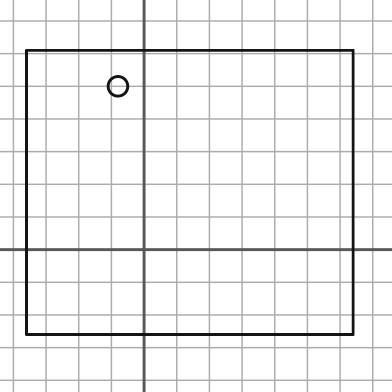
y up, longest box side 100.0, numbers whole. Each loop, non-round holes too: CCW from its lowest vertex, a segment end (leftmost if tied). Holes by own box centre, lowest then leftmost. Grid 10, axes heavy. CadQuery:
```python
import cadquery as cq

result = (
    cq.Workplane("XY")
    .moveTo(-36.0, -26.0)
    .lineTo(64.0, -26.0)
    .lineTo(64.0, 61.0)
    .lineTo(-36.0, 61.0)
    .close()
    .moveTo(-8.0, 50.0)
    .circle(3.0)
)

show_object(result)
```